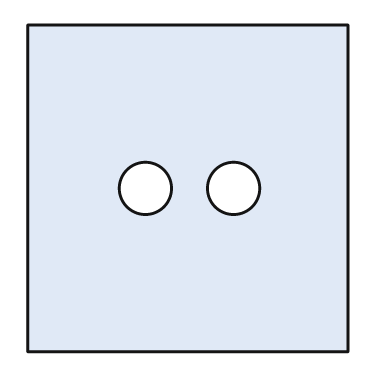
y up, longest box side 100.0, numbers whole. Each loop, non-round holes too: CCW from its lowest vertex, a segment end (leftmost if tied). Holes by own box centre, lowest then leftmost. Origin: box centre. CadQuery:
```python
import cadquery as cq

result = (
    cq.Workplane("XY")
    .moveTo(-49.0, -50.0)
    .lineTo(49.0, -50.0)
    .lineTo(49.0, 50.0)
    .lineTo(-49.0, 50.0)
    .close()
    .moveTo(-13.0, 0.0)
    .circle(8.0)
    .moveTo(14.0, 0.0)
    .circle(8.0)
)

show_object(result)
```